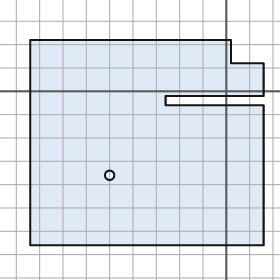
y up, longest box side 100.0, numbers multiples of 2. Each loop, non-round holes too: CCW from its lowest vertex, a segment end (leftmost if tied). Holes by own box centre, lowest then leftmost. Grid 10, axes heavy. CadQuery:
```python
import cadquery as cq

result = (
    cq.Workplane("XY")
    .moveTo(-84.0, -66.0)
    .lineTo(16.0, -66.0)
    .lineTo(16.0, -6.0)
    .lineTo(-26.0, -6.0)
    .lineTo(-26.0, -2.0)
    .lineTo(16.0, -2.0)
    .lineTo(16.0, 12.0)
    .lineTo(2.0, 12.0)
    .lineTo(2.0, 22.0)
    .lineTo(-84.0, 22.0)
    .close()
    .moveTo(-50.0, -36.0)
    .circle(2.0)
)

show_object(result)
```